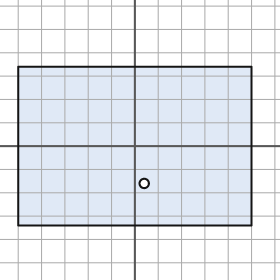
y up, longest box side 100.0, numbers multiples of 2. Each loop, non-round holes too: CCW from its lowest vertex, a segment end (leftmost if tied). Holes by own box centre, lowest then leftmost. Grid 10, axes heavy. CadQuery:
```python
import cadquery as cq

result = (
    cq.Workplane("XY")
    .moveTo(-50.0, -34.0)
    .lineTo(50.0, -34.0)
    .lineTo(50.0, 34.0)
    .lineTo(-50.0, 34.0)
    .close()
    .moveTo(4.0, -16.0)
    .circle(2.0)
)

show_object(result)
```